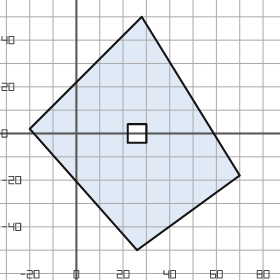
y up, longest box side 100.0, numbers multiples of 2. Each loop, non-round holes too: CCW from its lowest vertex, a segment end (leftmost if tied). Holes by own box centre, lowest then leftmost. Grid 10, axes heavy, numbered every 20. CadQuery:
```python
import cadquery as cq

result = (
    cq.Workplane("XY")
    .moveTo(26.0, -50.0)
    .lineTo(70.0, -18.0)
    .lineTo(28.0, 50.0)
    .lineTo(-20.0, 2.0)
    .close()
    .moveTo(22.0, -4.0)
    .lineTo(30.0, -4.0)
    .lineTo(30.0, 4.0)
    .lineTo(22.0, 4.0)
    .close()
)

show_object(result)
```